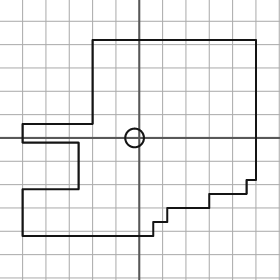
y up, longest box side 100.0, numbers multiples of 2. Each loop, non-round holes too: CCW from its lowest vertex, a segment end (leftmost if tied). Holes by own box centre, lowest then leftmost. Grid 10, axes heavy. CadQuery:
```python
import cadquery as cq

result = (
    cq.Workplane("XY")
    .moveTo(-50.0, -42.0)
    .lineTo(6.0, -42.0)
    .lineTo(6.0, -36.0)
    .lineTo(12.0, -36.0)
    .lineTo(12.0, -30.0)
    .lineTo(30.0, -30.0)
    .lineTo(30.0, -24.0)
    .lineTo(46.0, -24.0)
    .lineTo(46.0, -18.0)
    .lineTo(50.0, -18.0)
    .lineTo(50.0, 42.0)
    .lineTo(-20.0, 42.0)
    .lineTo(-20.0, 6.0)
    .lineTo(-50.0, 6.0)
    .lineTo(-50.0, -2.0)
    .lineTo(-26.0, -2.0)
    .lineTo(-26.0, -22.0)
    .lineTo(-50.0, -22.0)
    .close()
    .moveTo(-2.0, 0.0)
    .circle(4.0)
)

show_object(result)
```